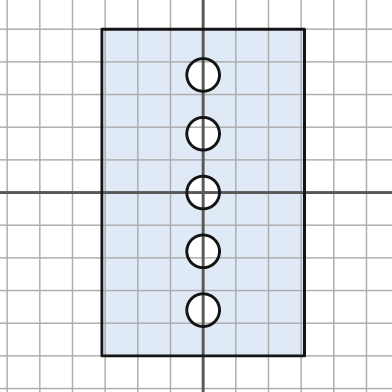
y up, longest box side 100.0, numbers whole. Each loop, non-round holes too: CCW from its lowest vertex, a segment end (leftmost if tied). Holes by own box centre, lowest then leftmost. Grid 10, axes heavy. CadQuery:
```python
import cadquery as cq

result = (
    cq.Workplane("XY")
    .moveTo(-31.0, -50.0)
    .lineTo(31.0, -50.0)
    .lineTo(31.0, 50.0)
    .lineTo(-31.0, 50.0)
    .close()
    .moveTo(0.0, -36.0)
    .circle(5.0)
    .moveTo(0.0, -18.0)
    .circle(5.0)
    .moveTo(0.0, 0.0)
    .circle(5.0)
    .moveTo(0.0, 18.0)
    .circle(5.0)
    .moveTo(0.0, 36.0)
    .circle(5.0)
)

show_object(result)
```